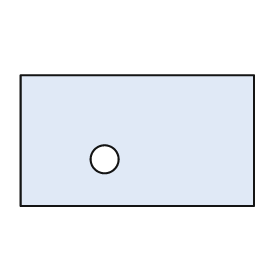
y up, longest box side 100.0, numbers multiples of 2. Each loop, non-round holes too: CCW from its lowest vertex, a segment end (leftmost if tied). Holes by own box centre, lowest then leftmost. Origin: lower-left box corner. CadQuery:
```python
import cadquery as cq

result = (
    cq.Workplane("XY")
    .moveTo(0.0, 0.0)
    .lineTo(100.0, 0.0)
    .lineTo(100.0, 56.0)
    .lineTo(0.0, 56.0)
    .close()
    .moveTo(36.0, 20.0)
    .circle(6.0)
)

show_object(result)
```